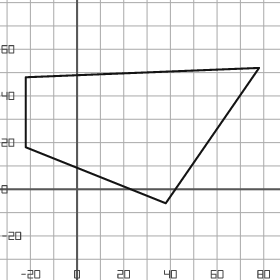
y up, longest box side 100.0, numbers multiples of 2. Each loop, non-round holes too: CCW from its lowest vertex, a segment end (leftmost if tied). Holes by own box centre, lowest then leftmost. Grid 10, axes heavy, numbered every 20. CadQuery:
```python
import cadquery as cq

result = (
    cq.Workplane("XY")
    .moveTo(38.0, -6.0)
    .lineTo(78.0, 52.0)
    .lineTo(-22.0, 48.0)
    .lineTo(-22.0, 18.0)
    .close()
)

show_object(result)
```